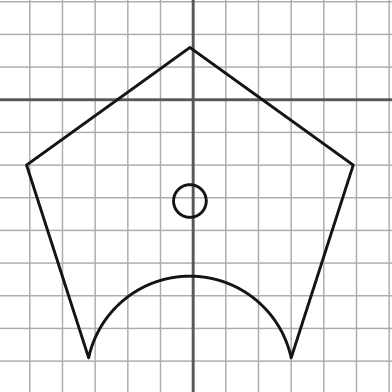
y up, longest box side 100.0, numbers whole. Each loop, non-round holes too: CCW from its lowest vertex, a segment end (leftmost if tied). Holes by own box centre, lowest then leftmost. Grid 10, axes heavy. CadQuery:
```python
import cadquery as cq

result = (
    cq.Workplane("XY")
    .moveTo(-32.0, -79.0)
    .threePointArc((-1.0, -54.0), (30.0, -79.0))
    .lineTo(49.0, -20.0)
    .lineTo(-1.0, 16.0)
    .lineTo(-51.0, -20.0)
    .close()
    .moveTo(-1.0, -31.0)
    .circle(5.0)
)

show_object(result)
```